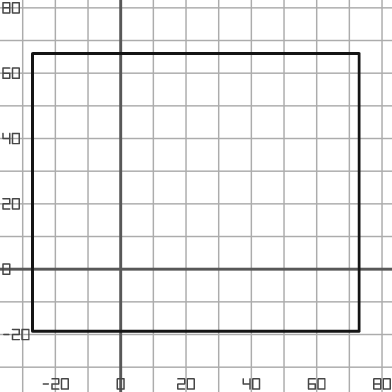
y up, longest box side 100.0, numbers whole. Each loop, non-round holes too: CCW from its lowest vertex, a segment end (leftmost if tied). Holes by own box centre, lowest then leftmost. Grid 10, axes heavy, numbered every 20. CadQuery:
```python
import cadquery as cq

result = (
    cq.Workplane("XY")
    .moveTo(-27.0, -19.0)
    .lineTo(73.0, -19.0)
    .lineTo(73.0, 66.0)
    .lineTo(-27.0, 66.0)
    .close()
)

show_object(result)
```